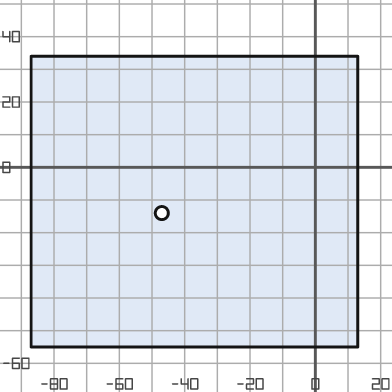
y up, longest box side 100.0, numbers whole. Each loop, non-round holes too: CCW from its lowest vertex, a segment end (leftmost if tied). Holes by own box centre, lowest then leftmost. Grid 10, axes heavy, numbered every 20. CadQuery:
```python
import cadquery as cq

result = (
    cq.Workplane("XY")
    .moveTo(-87.0, -55.0)
    .lineTo(13.0, -55.0)
    .lineTo(13.0, 34.0)
    .lineTo(-87.0, 34.0)
    .close()
    .moveTo(-47.0, -14.0)
    .circle(2.0)
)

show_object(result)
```